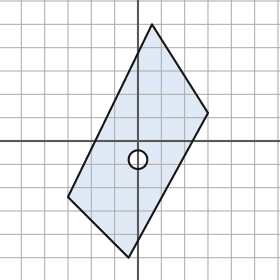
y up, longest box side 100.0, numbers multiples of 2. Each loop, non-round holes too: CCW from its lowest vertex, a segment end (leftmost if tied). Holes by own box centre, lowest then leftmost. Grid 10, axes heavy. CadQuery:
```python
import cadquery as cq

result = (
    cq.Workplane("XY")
    .moveTo(-4.0, -50.0)
    .lineTo(30.0, 12.0)
    .lineTo(6.0, 50.0)
    .lineTo(-30.0, -24.0)
    .close()
    .moveTo(0.0, -8.0)
    .circle(4.0)
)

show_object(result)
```